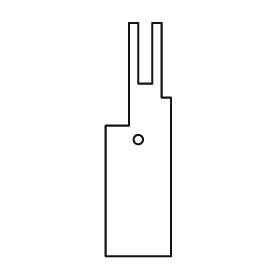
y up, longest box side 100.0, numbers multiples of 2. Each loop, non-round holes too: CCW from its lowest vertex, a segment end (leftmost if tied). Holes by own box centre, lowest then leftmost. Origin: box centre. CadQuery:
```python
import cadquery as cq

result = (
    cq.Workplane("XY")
    .moveTo(-14.0, -50.0)
    .lineTo(14.0, -50.0)
    .lineTo(14.0, 18.0)
    .lineTo(10.0, 18.0)
    .lineTo(10.0, 50.0)
    .lineTo(6.0, 50.0)
    .lineTo(6.0, 24.0)
    .lineTo(0.0, 24.0)
    .lineTo(0.0, 50.0)
    .lineTo(-4.0, 50.0)
    .lineTo(-4.0, 6.0)
    .lineTo(-14.0, 6.0)
    .close()
    .moveTo(0.0, 0.0)
    .circle(2.0)
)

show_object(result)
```